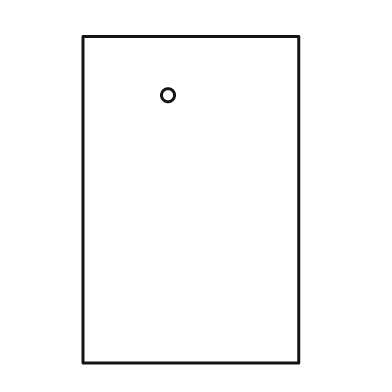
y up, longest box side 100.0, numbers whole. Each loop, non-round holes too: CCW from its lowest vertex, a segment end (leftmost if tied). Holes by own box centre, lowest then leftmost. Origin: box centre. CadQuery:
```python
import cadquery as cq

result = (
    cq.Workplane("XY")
    .moveTo(-33.0, -50.0)
    .lineTo(33.0, -50.0)
    .lineTo(33.0, 50.0)
    .lineTo(-33.0, 50.0)
    .close()
    .moveTo(-7.0, 32.0)
    .circle(2.0)
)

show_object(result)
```